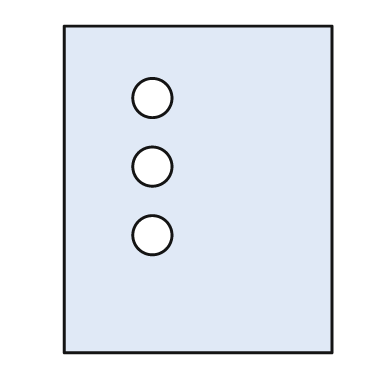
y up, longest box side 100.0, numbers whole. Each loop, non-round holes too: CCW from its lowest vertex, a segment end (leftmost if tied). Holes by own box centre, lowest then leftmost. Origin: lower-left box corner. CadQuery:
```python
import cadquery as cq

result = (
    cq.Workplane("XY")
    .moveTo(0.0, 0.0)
    .lineTo(82.0, 0.0)
    .lineTo(82.0, 100.0)
    .lineTo(0.0, 100.0)
    .close()
    .moveTo(27.0, 36.0)
    .circle(6.0)
    .moveTo(27.0, 57.0)
    .circle(6.0)
    .moveTo(27.0, 78.0)
    .circle(6.0)
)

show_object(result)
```